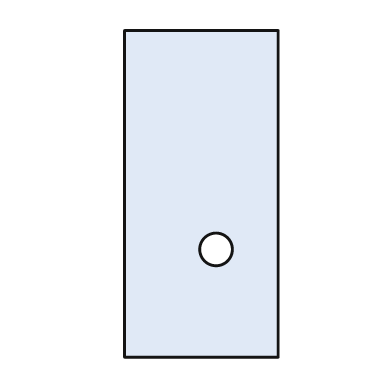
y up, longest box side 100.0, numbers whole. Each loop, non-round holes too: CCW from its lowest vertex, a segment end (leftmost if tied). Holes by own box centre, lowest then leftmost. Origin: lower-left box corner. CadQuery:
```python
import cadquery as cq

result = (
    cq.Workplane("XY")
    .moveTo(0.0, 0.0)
    .lineTo(47.0, 0.0)
    .lineTo(47.0, 100.0)
    .lineTo(0.0, 100.0)
    .close()
    .moveTo(28.0, 33.0)
    .circle(5.0)
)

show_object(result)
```